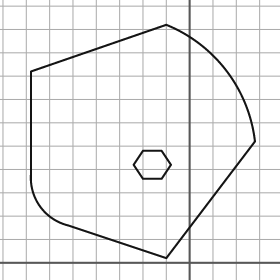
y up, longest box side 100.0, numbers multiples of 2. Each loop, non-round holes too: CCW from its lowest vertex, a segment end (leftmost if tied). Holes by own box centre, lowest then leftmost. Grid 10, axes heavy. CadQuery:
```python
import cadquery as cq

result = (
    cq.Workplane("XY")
    .moveTo(-10.0, 2.0)
    .lineTo(28.0, 52.0)
    .threePointArc((16.0, 82.0), (-10.0, 102.0))
    .lineTo(-68.0, 82.0)
    .lineTo(-68.0, 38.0)
    .threePointArc((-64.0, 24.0), (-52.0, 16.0))
    .close()
    .moveTo(-20.0, 36.0)
    .lineTo(-12.0, 36.0)
    .lineTo(-8.0, 42.0)
    .lineTo(-12.0, 48.0)
    .lineTo(-20.0, 48.0)
    .lineTo(-24.0, 42.0)
    .close()
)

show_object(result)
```